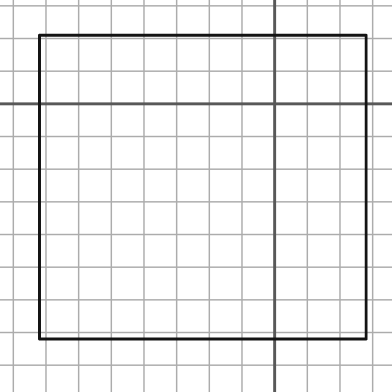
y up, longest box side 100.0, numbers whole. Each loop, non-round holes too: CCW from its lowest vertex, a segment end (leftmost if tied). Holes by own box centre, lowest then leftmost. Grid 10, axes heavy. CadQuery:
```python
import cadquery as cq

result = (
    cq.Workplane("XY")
    .moveTo(-72.0, -72.0)
    .lineTo(28.0, -72.0)
    .lineTo(28.0, 21.0)
    .lineTo(-72.0, 21.0)
    .close()
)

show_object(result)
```